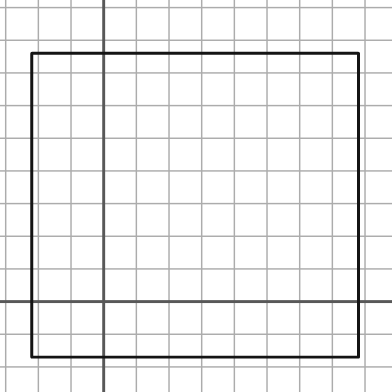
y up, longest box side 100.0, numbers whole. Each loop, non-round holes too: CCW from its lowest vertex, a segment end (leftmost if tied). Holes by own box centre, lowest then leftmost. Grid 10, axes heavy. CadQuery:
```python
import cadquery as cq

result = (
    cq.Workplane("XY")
    .moveTo(-22.0, -17.0)
    .lineTo(78.0, -17.0)
    .lineTo(78.0, 76.0)
    .lineTo(-22.0, 76.0)
    .close()
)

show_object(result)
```